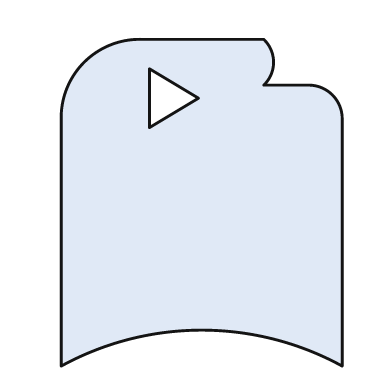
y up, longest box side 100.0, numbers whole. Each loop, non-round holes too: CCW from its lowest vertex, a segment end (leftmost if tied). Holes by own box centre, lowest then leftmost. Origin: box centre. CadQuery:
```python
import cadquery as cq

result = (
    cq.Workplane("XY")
    .moveTo(-43.0, -50.0)
    .threePointArc((0.0, -39.0), (43.0, -50.0))
    .lineTo(43.0, 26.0)
    .threePointArc((40.0, 33.0), (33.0, 36.0))
    .lineTo(19.0, 36.0)
    .threePointArc((22.0, 43.0), (19.0, 50.0))
    .lineTo(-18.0, 50.0)
    .threePointArc((-36.0, 43.0), (-43.0, 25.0))
    .close()
    .moveTo(-16.0, 23.0)
    .lineTo(-1.0, 32.0)
    .lineTo(-16.0, 41.0)
    .close()
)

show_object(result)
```